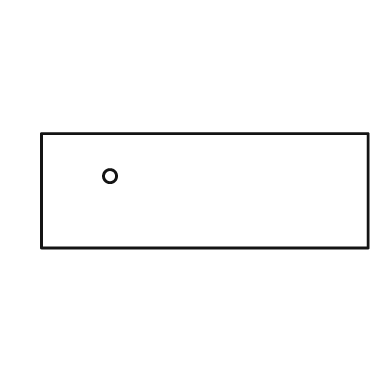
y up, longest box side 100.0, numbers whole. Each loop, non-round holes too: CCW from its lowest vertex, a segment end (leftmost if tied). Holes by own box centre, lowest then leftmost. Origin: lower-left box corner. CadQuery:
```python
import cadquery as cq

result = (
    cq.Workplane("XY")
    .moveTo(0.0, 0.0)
    .lineTo(100.0, 0.0)
    .lineTo(100.0, 35.0)
    .lineTo(0.0, 35.0)
    .close()
    .moveTo(21.0, 22.0)
    .circle(2.0)
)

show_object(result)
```